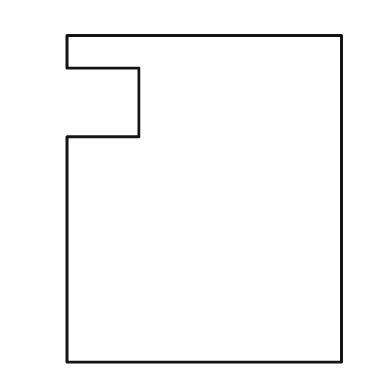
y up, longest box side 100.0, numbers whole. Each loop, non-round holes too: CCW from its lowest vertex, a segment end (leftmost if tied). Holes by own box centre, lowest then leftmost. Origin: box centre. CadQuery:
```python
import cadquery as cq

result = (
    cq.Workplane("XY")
    .moveTo(-42.0, -50.0)
    .lineTo(42.0, -50.0)
    .lineTo(42.0, 50.0)
    .lineTo(-42.0, 50.0)
    .lineTo(-42.0, 40.0)
    .lineTo(-20.0, 40.0)
    .lineTo(-20.0, 19.0)
    .lineTo(-42.0, 19.0)
    .close()
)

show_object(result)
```